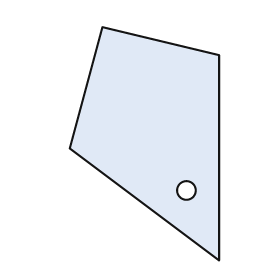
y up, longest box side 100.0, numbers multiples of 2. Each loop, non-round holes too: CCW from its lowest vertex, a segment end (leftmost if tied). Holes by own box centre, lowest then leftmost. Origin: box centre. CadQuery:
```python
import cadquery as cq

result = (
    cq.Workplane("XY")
    .moveTo(32.0, -50.0)
    .lineTo(32.0, 38.0)
    .lineTo(-18.0, 50.0)
    .lineTo(-32.0, -2.0)
    .close()
    .moveTo(18.0, -20.0)
    .circle(4.0)
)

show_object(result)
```